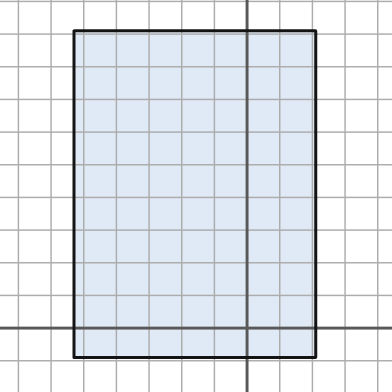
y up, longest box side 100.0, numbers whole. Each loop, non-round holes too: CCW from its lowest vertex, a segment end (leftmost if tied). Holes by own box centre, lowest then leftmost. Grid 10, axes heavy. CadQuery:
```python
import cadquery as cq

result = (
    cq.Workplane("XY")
    .moveTo(-53.0, -9.0)
    .lineTo(21.0, -9.0)
    .lineTo(21.0, 91.0)
    .lineTo(-53.0, 91.0)
    .close()
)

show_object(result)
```